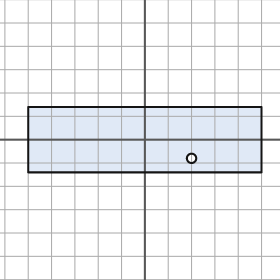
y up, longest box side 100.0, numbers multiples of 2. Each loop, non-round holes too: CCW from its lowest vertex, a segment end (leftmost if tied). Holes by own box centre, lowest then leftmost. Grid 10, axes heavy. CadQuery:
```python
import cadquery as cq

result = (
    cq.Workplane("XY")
    .moveTo(-50.0, -14.0)
    .lineTo(50.0, -14.0)
    .lineTo(50.0, 14.0)
    .lineTo(-50.0, 14.0)
    .close()
    .moveTo(20.0, -8.0)
    .circle(2.0)
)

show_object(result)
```